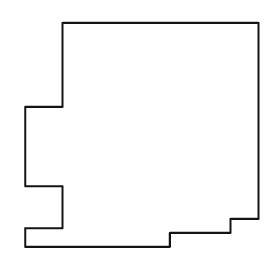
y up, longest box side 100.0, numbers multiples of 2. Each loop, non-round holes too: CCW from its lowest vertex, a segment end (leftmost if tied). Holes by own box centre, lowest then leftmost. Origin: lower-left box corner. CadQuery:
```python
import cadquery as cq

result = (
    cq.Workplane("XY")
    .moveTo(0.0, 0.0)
    .lineTo(62.0, 0.0)
    .lineTo(62.0, 6.0)
    .lineTo(88.0, 6.0)
    .lineTo(88.0, 12.0)
    .lineTo(100.0, 12.0)
    .lineTo(100.0, 96.0)
    .lineTo(16.0, 96.0)
    .lineTo(16.0, 60.0)
    .lineTo(0.0, 60.0)
    .lineTo(0.0, 26.0)
    .lineTo(16.0, 26.0)
    .lineTo(16.0, 8.0)
    .lineTo(0.0, 8.0)
    .close()
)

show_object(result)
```